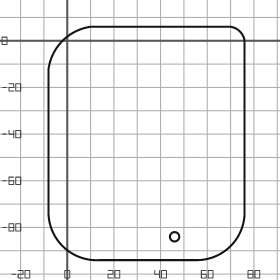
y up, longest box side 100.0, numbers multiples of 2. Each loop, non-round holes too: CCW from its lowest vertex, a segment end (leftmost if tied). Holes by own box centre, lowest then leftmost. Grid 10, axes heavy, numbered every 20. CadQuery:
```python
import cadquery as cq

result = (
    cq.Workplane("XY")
    .moveTo(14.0, -94.0)
    .lineTo(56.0, -94.0)
    .threePointArc((70.0, -88.0), (76.0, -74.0))
    .lineTo(76.0, 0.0)
    .threePointArc((74.0, 4.0), (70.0, 6.0))
    .lineTo(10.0, 6.0)
    .threePointArc((-2.0, 0.0), (-8.0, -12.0))
    .lineTo(-8.0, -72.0)
    .threePointArc((-2.0, -88.0), (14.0, -94.0))
    .close()
    .moveTo(46.0, -84.0)
    .circle(2.0)
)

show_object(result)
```